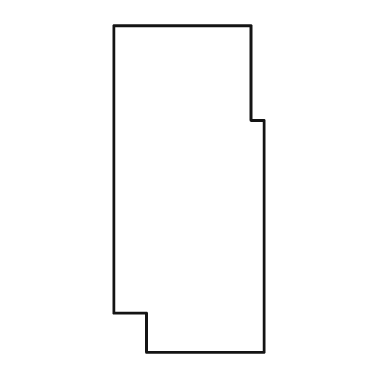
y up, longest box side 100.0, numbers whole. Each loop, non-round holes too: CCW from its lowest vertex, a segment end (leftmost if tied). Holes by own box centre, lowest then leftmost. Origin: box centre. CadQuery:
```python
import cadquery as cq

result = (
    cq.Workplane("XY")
    .moveTo(-13.0, -50.0)
    .lineTo(23.0, -50.0)
    .lineTo(23.0, 21.0)
    .lineTo(19.0, 21.0)
    .lineTo(19.0, 50.0)
    .lineTo(-23.0, 50.0)
    .lineTo(-23.0, -38.0)
    .lineTo(-13.0, -38.0)
    .close()
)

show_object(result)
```